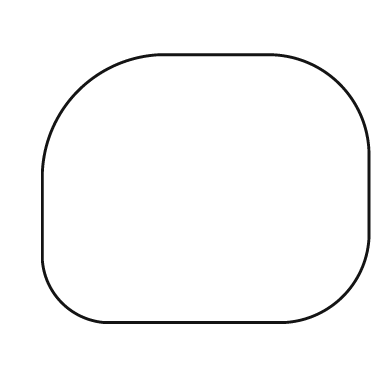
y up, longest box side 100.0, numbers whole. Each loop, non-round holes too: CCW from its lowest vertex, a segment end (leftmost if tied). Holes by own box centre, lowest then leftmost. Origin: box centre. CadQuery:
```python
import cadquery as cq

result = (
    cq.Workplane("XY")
    .moveTo(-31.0, -41.0)
    .lineTo(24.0, -41.0)
    .threePointArc((42.0, -33.0), (50.0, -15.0))
    .lineTo(50.0, 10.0)
    .threePointArc((41.0, 32.0), (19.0, 41.0))
    .lineTo(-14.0, 41.0)
    .threePointArc((-39.0, 30.0), (-50.0, 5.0))
    .lineTo(-50.0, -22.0)
    .threePointArc((-44.0, -35.0), (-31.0, -41.0))
    .close()
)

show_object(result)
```